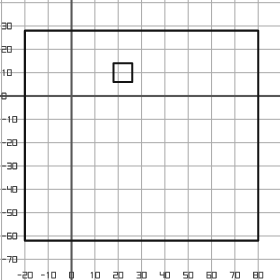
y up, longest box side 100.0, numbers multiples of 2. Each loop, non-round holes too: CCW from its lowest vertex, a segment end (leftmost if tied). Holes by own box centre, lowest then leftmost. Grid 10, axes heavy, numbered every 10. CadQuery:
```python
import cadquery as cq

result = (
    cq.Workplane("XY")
    .moveTo(-20.0, -62.0)
    .lineTo(80.0, -62.0)
    .lineTo(80.0, 28.0)
    .lineTo(-20.0, 28.0)
    .close()
    .moveTo(18.0, 6.0)
    .lineTo(26.0, 6.0)
    .lineTo(26.0, 14.0)
    .lineTo(18.0, 14.0)
    .close()
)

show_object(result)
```